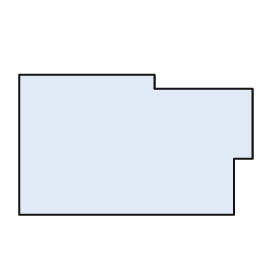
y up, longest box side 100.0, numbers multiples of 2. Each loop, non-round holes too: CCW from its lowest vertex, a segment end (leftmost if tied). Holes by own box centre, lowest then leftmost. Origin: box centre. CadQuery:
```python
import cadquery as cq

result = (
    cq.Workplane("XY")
    .moveTo(-50.0, -30.0)
    .lineTo(42.0, -30.0)
    .lineTo(42.0, -6.0)
    .lineTo(50.0, -6.0)
    .lineTo(50.0, 24.0)
    .lineTo(8.0, 24.0)
    .lineTo(8.0, 30.0)
    .lineTo(-50.0, 30.0)
    .close()
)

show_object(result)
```